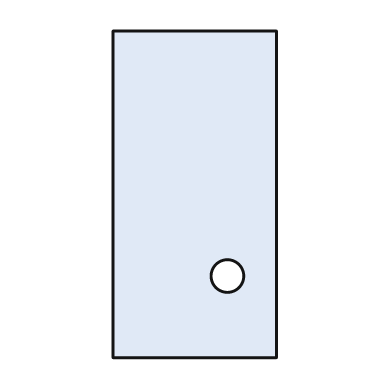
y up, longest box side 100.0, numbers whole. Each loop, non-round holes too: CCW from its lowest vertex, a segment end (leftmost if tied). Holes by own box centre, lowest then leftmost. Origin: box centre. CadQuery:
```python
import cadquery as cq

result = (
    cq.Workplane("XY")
    .moveTo(-25.0, -50.0)
    .lineTo(25.0, -50.0)
    .lineTo(25.0, 50.0)
    .lineTo(-25.0, 50.0)
    .close()
    .moveTo(10.0, -25.0)
    .circle(5.0)
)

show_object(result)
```